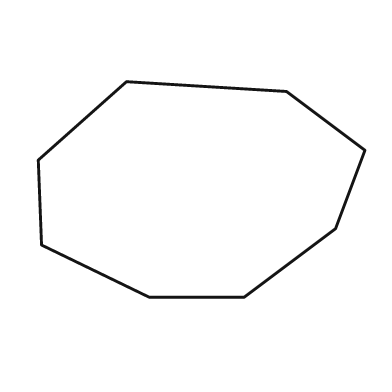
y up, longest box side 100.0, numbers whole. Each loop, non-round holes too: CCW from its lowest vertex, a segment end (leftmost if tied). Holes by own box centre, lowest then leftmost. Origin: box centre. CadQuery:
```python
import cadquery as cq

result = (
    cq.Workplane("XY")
    .moveTo(-16.0, -33.0)
    .lineTo(13.0, -33.0)
    .lineTo(41.0, -12.0)
    .lineTo(50.0, 12.0)
    .lineTo(26.0, 30.0)
    .lineTo(-23.0, 33.0)
    .lineTo(-50.0, 9.0)
    .lineTo(-49.0, -17.0)
    .close()
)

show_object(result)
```